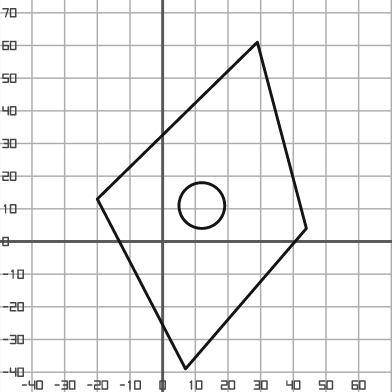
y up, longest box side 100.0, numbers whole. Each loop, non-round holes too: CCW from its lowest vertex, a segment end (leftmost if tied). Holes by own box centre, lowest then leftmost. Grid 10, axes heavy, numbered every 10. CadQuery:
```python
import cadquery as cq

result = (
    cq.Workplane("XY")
    .moveTo(7.0, -39.0)
    .lineTo(44.0, 4.0)
    .lineTo(29.0, 61.0)
    .lineTo(-20.0, 13.0)
    .close()
    .moveTo(12.0, 11.0)
    .circle(7.0)
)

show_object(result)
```